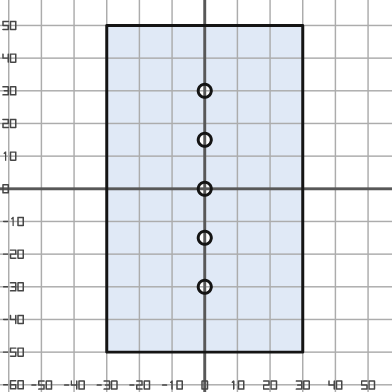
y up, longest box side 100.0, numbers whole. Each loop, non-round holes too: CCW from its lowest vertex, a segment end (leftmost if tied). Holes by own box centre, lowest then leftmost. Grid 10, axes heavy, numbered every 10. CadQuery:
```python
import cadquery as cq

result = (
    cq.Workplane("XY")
    .moveTo(-30.0, -50.0)
    .lineTo(30.0, -50.0)
    .lineTo(30.0, 50.0)
    .lineTo(-30.0, 50.0)
    .close()
    .moveTo(0.0, -30.0)
    .circle(2.0)
    .moveTo(0.0, -15.0)
    .circle(2.0)
    .moveTo(0.0, 0.0)
    .circle(2.0)
    .moveTo(0.0, 15.0)
    .circle(2.0)
    .moveTo(0.0, 30.0)
    .circle(2.0)
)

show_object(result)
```